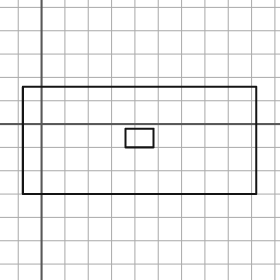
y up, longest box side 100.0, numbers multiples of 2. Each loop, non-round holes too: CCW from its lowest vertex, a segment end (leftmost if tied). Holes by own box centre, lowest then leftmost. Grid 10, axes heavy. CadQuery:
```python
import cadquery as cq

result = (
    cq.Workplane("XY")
    .moveTo(-8.0, -30.0)
    .lineTo(92.0, -30.0)
    .lineTo(92.0, 16.0)
    .lineTo(-8.0, 16.0)
    .close()
    .moveTo(36.0, -10.0)
    .lineTo(48.0, -10.0)
    .lineTo(48.0, -2.0)
    .lineTo(36.0, -2.0)
    .close()
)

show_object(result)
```